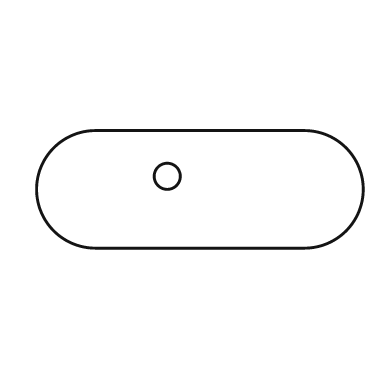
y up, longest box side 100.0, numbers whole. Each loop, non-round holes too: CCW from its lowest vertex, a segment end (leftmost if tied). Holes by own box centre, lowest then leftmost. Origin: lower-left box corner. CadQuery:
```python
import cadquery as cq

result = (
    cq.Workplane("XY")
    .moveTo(18.0, 0.0)
    .lineTo(82.0, 0.0)
    .threePointArc((100.0, 18.0), (82.0, 36.0))
    .lineTo(18.0, 36.0)
    .threePointArc((0.0, 18.0), (18.0, 0.0))
    .close()
    .moveTo(40.0, 22.0)
    .circle(4.0)
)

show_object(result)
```